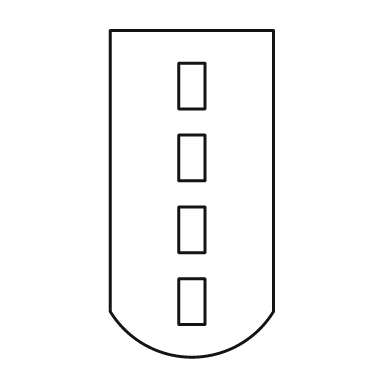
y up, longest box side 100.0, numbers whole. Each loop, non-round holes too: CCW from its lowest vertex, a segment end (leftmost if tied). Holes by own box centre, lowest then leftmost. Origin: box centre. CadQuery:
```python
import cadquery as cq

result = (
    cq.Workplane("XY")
    .moveTo(-25.0, -36.0)
    .threePointArc((0.0, -50.0), (25.0, -36.0))
    .lineTo(25.0, 50.0)
    .lineTo(-25.0, 50.0)
    .close()
    .moveTo(-4.0, -40.0)
    .lineTo(4.0, -40.0)
    .lineTo(4.0, -26.0)
    .lineTo(-4.0, -26.0)
    .close()
    .moveTo(-4.0, -18.0)
    .lineTo(4.0, -18.0)
    .lineTo(4.0, -4.0)
    .lineTo(-4.0, -4.0)
    .close()
    .moveTo(-4.0, 4.0)
    .lineTo(4.0, 4.0)
    .lineTo(4.0, 18.0)
    .lineTo(-4.0, 18.0)
    .close()
    .moveTo(-4.0, 26.0)
    .lineTo(4.0, 26.0)
    .lineTo(4.0, 40.0)
    .lineTo(-4.0, 40.0)
    .close()
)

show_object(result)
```